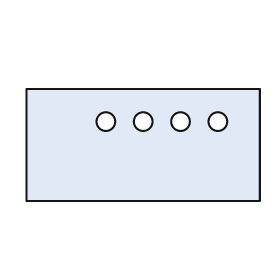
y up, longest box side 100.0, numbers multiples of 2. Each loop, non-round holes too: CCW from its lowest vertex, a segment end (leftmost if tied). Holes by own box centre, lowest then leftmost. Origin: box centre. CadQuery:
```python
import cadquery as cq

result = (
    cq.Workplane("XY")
    .moveTo(-50.0, -24.0)
    .lineTo(50.0, -24.0)
    .lineTo(50.0, 24.0)
    .lineTo(-50.0, 24.0)
    .close()
    .moveTo(-16.0, 10.0)
    .circle(4.0)
    .moveTo(0.0, 10.0)
    .circle(4.0)
    .moveTo(16.0, 10.0)
    .circle(4.0)
    .moveTo(32.0, 10.0)
    .circle(4.0)
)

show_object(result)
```